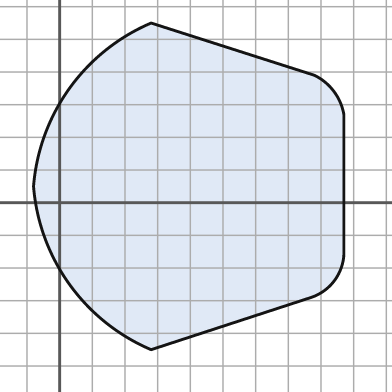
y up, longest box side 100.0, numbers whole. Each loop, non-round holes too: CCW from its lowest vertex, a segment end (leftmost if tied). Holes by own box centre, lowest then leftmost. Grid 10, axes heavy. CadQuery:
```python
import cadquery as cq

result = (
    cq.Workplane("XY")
    .moveTo(28.0, -45.0)
    .lineTo(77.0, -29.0)
    .threePointArc((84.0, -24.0), (87.0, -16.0))
    .lineTo(87.0, 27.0)
    .threePointArc((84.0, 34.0), (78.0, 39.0))
    .lineTo(28.0, 55.0)
    .threePointArc((3.0, 35.0), (-8.0, 5.0))
    .threePointArc((3.0, -25.0), (28.0, -45.0))
    .close()
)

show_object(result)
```